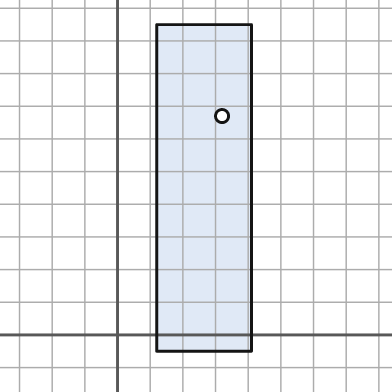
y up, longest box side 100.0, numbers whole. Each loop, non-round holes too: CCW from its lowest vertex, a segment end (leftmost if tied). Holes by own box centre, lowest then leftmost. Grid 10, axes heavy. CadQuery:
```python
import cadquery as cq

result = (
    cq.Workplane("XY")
    .moveTo(12.0, -5.0)
    .lineTo(41.0, -5.0)
    .lineTo(41.0, 95.0)
    .lineTo(12.0, 95.0)
    .close()
    .moveTo(32.0, 67.0)
    .circle(2.0)
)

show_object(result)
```